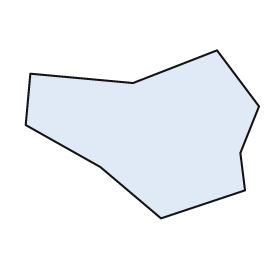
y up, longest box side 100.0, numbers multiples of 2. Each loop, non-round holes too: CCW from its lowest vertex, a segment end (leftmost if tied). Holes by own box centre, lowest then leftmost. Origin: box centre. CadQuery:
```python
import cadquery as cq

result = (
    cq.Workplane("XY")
    .moveTo(8.0, -36.0)
    .lineTo(44.0, -24.0)
    .lineTo(42.0, -8.0)
    .lineTo(50.0, 12.0)
    .lineTo(32.0, 36.0)
    .lineTo(-4.0, 22.0)
    .lineTo(-48.0, 26.0)
    .lineTo(-50.0, 4.0)
    .lineTo(-18.0, -14.0)
    .close()
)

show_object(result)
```